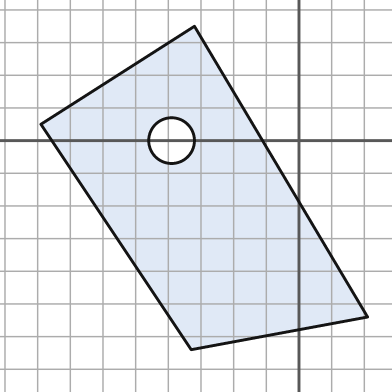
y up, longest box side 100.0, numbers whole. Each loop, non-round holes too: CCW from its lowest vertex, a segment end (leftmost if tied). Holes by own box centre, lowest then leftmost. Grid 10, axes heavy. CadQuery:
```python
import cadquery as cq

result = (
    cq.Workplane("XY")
    .moveTo(-33.0, -64.0)
    .lineTo(21.0, -54.0)
    .lineTo(-32.0, 35.0)
    .lineTo(-79.0, 5.0)
    .close()
    .moveTo(-39.0, 0.0)
    .circle(7.0)
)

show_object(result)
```